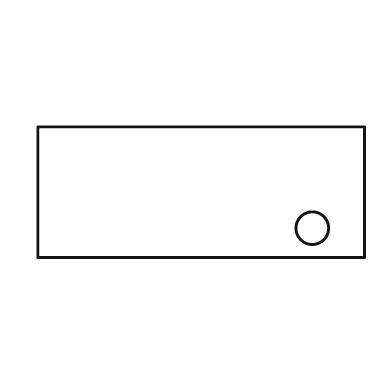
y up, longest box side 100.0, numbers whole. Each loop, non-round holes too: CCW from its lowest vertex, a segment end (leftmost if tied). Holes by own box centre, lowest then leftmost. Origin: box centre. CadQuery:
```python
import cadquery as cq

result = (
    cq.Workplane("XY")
    .moveTo(-50.0, -20.0)
    .lineTo(50.0, -20.0)
    .lineTo(50.0, 20.0)
    .lineTo(-50.0, 20.0)
    .close()
    .moveTo(34.0, -11.0)
    .circle(5.0)
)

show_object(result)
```